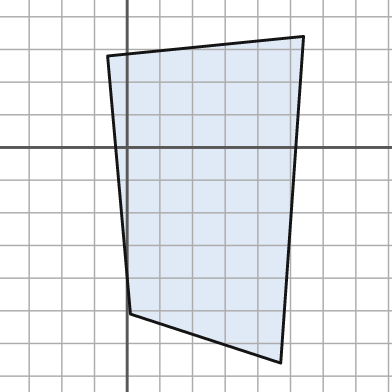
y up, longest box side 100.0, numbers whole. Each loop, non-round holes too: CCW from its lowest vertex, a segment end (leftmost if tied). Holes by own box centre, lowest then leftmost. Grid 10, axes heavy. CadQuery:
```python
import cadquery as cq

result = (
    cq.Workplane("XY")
    .moveTo(47.0, -66.0)
    .lineTo(54.0, 34.0)
    .lineTo(-6.0, 28.0)
    .lineTo(1.0, -51.0)
    .close()
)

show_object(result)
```